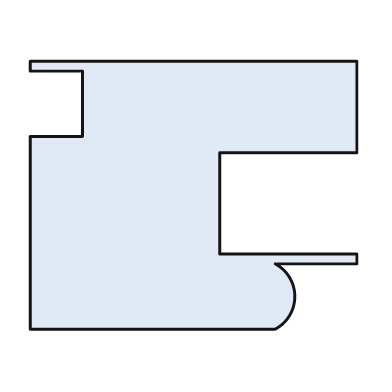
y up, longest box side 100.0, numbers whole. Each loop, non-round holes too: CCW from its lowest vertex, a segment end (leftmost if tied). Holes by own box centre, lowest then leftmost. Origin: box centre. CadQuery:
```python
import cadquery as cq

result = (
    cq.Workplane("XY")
    .moveTo(-50.0, -41.0)
    .lineTo(25.0, -41.0)
    .threePointArc((31.0, -31.0), (25.0, -21.0))
    .lineTo(50.0, -21.0)
    .lineTo(50.0, -18.0)
    .lineTo(8.0, -18.0)
    .lineTo(8.0, 13.0)
    .lineTo(50.0, 13.0)
    .lineTo(50.0, 41.0)
    .lineTo(-50.0, 41.0)
    .lineTo(-50.0, 38.0)
    .lineTo(-34.0, 38.0)
    .lineTo(-34.0, 18.0)
    .lineTo(-50.0, 18.0)
    .close()
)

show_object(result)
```